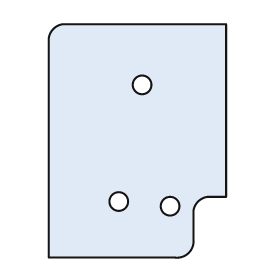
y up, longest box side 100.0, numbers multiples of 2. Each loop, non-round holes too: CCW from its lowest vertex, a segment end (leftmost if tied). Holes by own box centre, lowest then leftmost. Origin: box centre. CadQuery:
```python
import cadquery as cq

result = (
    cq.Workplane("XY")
    .moveTo(-38.0, -50.0)
    .lineTo(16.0, -50.0)
    .threePointArc((22.0, -48.0), (24.0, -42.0))
    .lineTo(24.0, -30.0)
    .threePointArc((26.0, -26.0), (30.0, -24.0))
    .lineTo(38.0, -24.0)
    .lineTo(38.0, 50.0)
    .lineTo(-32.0, 50.0)
    .threePointArc((-36.0, 48.0), (-38.0, 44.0))
    .close()
    .moveTo(14.0, -28.0)
    .circle(4.0)
    .moveTo(-8.0, -26.0)
    .circle(4.0)
    .moveTo(2.0, 24.0)
    .circle(4.0)
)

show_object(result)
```